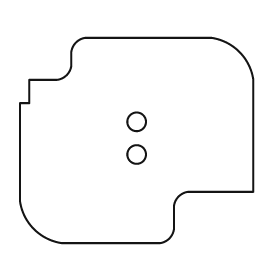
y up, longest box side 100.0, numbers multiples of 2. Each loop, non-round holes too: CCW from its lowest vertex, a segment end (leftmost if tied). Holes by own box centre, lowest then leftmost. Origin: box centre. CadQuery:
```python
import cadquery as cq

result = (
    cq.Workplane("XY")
    .moveTo(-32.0, -44.0)
    .lineTo(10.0, -44.0)
    .threePointArc((14.0, -42.0), (16.0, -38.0))
    .lineTo(16.0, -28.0)
    .threePointArc((18.0, -24.0), (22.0, -22.0))
    .lineTo(50.0, -22.0)
    .lineTo(50.0, 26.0)
    .threePointArc((44.0, 38.0), (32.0, 44.0))
    .lineTo(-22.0, 44.0)
    .threePointArc((-26.0, 42.0), (-28.0, 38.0))
    .lineTo(-28.0, 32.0)
    .threePointArc((-30.0, 28.0), (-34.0, 26.0))
    .lineTo(-46.0, 26.0)
    .lineTo(-46.0, 16.0)
    .lineTo(-50.0, 16.0)
    .lineTo(-50.0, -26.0)
    .threePointArc((-44.0, -38.0), (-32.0, -44.0))
    .close()
    .moveTo(0.0, -6.0)
    .circle(4.0)
    .moveTo(0.0, 8.0)
    .circle(4.0)
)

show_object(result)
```